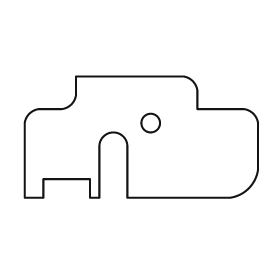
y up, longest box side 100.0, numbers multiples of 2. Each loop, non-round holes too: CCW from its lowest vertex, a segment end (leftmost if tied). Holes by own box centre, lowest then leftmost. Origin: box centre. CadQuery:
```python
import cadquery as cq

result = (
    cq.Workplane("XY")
    .moveTo(-50.0, -26.0)
    .lineTo(-42.0, -26.0)
    .lineTo(-42.0, -18.0)
    .lineTo(-22.0, -18.0)
    .lineTo(-22.0, -26.0)
    .lineTo(-18.0, -26.0)
    .lineTo(-18.0, -4.0)
    .threePointArc((-12.0, 2.0), (-6.0, -4.0))
    .lineTo(-6.0, -26.0)
    .lineTo(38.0, -26.0)
    .threePointArc((46.0, -22.0), (50.0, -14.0))
    .lineTo(50.0, 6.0)
    .threePointArc((48.0, 10.0), (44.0, 12.0))
    .lineTo(24.0, 12.0)
    .lineTo(24.0, 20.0)
    .threePointArc((22.0, 24.0), (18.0, 26.0))
    .lineTo(-28.0, 26.0)
    .lineTo(-28.0, 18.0)
    .threePointArc((-30.0, 14.0), (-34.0, 12.0))
    .lineTo(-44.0, 12.0)
    .threePointArc((-48.0, 10.0), (-50.0, 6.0))
    .close()
    .moveTo(4.0, 6.0)
    .circle(4.0)
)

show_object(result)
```